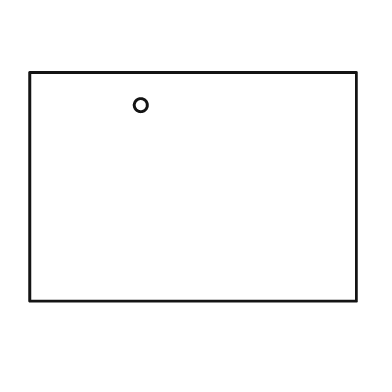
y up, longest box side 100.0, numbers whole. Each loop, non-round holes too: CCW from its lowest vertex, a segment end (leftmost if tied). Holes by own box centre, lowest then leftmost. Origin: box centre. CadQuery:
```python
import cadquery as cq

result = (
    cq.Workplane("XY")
    .moveTo(-50.0, -35.0)
    .lineTo(50.0, -35.0)
    .lineTo(50.0, 35.0)
    .lineTo(-50.0, 35.0)
    .close()
    .moveTo(-16.0, 25.0)
    .circle(2.0)
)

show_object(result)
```